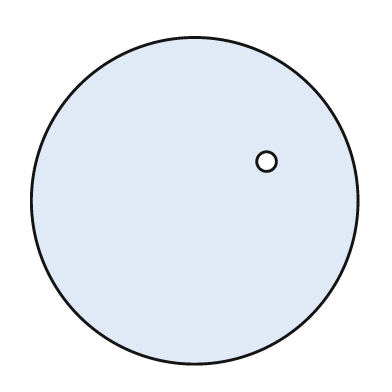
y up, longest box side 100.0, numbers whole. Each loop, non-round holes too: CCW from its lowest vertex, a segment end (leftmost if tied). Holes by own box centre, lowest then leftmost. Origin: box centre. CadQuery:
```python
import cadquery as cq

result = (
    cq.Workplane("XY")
    .moveTo(0.0, 0.0)
    .circle(50.0)
    .moveTo(22.0, 12.0)
    .circle(3.0)
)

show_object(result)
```